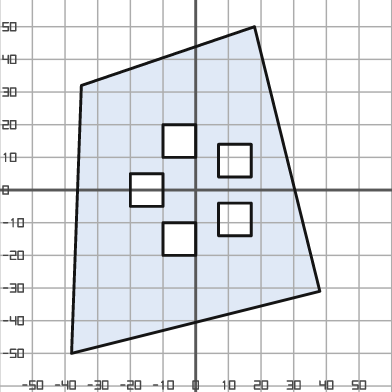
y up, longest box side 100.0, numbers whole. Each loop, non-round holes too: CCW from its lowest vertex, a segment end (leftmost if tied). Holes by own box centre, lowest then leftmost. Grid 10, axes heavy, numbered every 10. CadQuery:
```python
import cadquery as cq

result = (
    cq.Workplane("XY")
    .moveTo(-38.0, -50.0)
    .lineTo(38.0, -31.0)
    .lineTo(18.0, 50.0)
    .lineTo(-35.0, 32.0)
    .close()
    .moveTo(-10.0, -20.0)
    .lineTo(0.0, -20.0)
    .lineTo(0.0, -10.0)
    .lineTo(-10.0, -10.0)
    .close()
    .moveTo(7.0, -14.0)
    .lineTo(17.0, -14.0)
    .lineTo(17.0, -4.0)
    .lineTo(7.0, -4.0)
    .close()
    .moveTo(-20.0, -5.0)
    .lineTo(-10.0, -5.0)
    .lineTo(-10.0, 5.0)
    .lineTo(-20.0, 5.0)
    .close()
    .moveTo(7.0, 4.0)
    .lineTo(17.0, 4.0)
    .lineTo(17.0, 14.0)
    .lineTo(7.0, 14.0)
    .close()
    .moveTo(-10.0, 10.0)
    .lineTo(0.0, 10.0)
    .lineTo(0.0, 20.0)
    .lineTo(-10.0, 20.0)
    .close()
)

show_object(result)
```